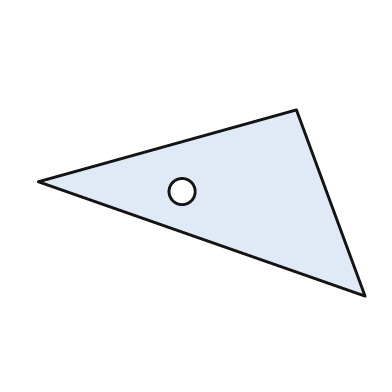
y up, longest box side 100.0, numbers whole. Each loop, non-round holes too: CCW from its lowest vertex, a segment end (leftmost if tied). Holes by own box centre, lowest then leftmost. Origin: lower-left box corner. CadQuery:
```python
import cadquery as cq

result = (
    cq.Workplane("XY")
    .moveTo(100.0, 0.0)
    .lineTo(79.0, 57.0)
    .lineTo(0.0, 35.0)
    .close()
    .moveTo(44.0, 32.0)
    .circle(4.0)
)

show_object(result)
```